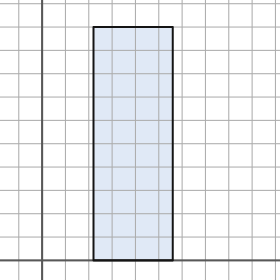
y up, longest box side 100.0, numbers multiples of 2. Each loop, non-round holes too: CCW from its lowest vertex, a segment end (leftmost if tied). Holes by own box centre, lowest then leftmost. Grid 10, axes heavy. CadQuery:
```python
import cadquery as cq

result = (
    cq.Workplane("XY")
    .moveTo(22.0, 0.0)
    .lineTo(56.0, 0.0)
    .lineTo(56.0, 100.0)
    .lineTo(22.0, 100.0)
    .close()
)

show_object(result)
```